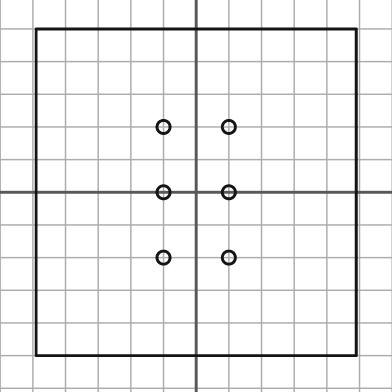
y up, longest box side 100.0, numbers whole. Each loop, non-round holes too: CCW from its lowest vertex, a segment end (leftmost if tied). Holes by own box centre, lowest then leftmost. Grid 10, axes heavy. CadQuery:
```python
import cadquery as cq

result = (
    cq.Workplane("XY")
    .moveTo(-49.0, -50.0)
    .lineTo(49.0, -50.0)
    .lineTo(49.0, 50.0)
    .lineTo(-49.0, 50.0)
    .close()
    .moveTo(-10.0, -20.0)
    .circle(2.0)
    .moveTo(10.0, -20.0)
    .circle(2.0)
    .moveTo(-10.0, 0.0)
    .circle(2.0)
    .moveTo(10.0, 0.0)
    .circle(2.0)
    .moveTo(-10.0, 20.0)
    .circle(2.0)
    .moveTo(10.0, 20.0)
    .circle(2.0)
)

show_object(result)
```